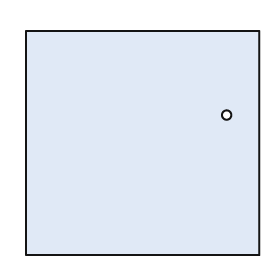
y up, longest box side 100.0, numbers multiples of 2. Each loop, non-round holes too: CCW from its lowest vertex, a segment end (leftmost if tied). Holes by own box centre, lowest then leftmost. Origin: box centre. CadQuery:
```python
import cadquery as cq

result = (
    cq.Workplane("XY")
    .moveTo(-50.0, -48.0)
    .lineTo(50.0, -48.0)
    .lineTo(50.0, 48.0)
    .lineTo(-50.0, 48.0)
    .close()
    .moveTo(36.0, 12.0)
    .circle(2.0)
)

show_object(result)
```